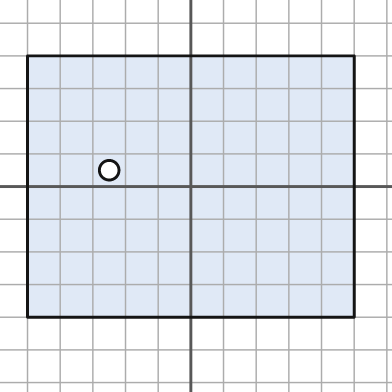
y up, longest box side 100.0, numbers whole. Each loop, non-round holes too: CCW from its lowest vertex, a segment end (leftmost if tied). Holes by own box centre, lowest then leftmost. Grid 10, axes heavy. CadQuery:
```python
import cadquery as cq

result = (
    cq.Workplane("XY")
    .moveTo(-50.0, -40.0)
    .lineTo(50.0, -40.0)
    .lineTo(50.0, 40.0)
    .lineTo(-50.0, 40.0)
    .close()
    .moveTo(-25.0, 5.0)
    .circle(3.0)
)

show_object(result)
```